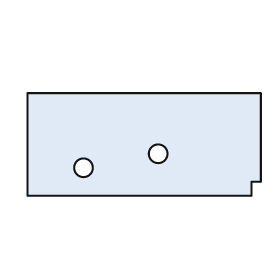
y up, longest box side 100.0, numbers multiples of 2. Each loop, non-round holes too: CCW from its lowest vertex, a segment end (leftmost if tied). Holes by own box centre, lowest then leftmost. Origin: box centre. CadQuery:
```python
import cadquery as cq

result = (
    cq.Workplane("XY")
    .moveTo(-50.0, -22.0)
    .lineTo(46.0, -22.0)
    .lineTo(46.0, -16.0)
    .lineTo(50.0, -16.0)
    .lineTo(50.0, 22.0)
    .lineTo(-50.0, 22.0)
    .close()
    .moveTo(-26.0, -10.0)
    .circle(4.0)
    .moveTo(6.0, -4.0)
    .circle(4.0)
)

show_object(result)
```